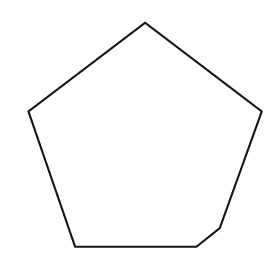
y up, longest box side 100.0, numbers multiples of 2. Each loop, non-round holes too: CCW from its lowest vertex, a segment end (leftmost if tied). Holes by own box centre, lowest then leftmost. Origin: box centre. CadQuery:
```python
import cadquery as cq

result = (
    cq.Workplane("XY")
    .moveTo(-30.0, -48.0)
    .lineTo(22.0, -48.0)
    .lineTo(32.0, -40.0)
    .lineTo(50.0, 10.0)
    .lineTo(0.0, 48.0)
    .lineTo(-50.0, 10.0)
    .close()
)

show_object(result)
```